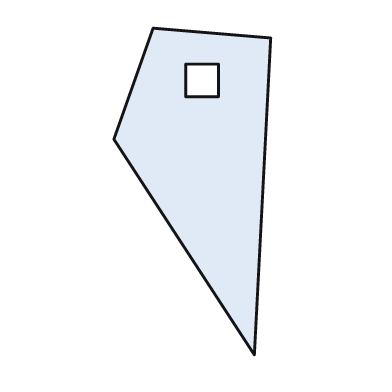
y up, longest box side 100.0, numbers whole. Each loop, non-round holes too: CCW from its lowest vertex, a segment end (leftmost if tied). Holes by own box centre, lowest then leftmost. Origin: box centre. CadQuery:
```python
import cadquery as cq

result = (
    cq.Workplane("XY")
    .moveTo(19.0, -50.0)
    .lineTo(24.0, 47.0)
    .lineTo(-12.0, 50.0)
    .lineTo(-24.0, 16.0)
    .close()
    .moveTo(-2.0, 29.0)
    .lineTo(8.0, 29.0)
    .lineTo(8.0, 39.0)
    .lineTo(-2.0, 39.0)
    .close()
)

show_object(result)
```